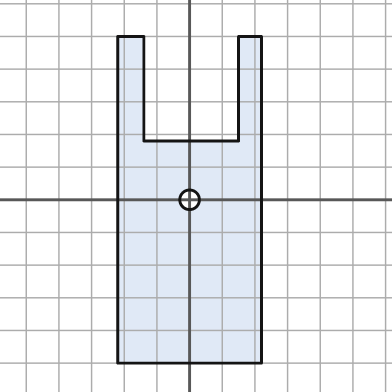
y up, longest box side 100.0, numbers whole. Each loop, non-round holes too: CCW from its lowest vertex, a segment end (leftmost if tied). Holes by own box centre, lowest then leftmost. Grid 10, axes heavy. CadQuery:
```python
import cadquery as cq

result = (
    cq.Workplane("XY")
    .moveTo(-22.0, -50.0)
    .lineTo(22.0, -50.0)
    .lineTo(22.0, 50.0)
    .lineTo(15.0, 50.0)
    .lineTo(15.0, 18.0)
    .lineTo(-14.0, 18.0)
    .lineTo(-14.0, 50.0)
    .lineTo(-22.0, 50.0)
    .close()
    .moveTo(0.0, 0.0)
    .circle(3.0)
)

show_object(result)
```